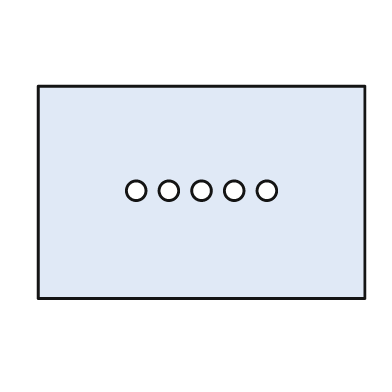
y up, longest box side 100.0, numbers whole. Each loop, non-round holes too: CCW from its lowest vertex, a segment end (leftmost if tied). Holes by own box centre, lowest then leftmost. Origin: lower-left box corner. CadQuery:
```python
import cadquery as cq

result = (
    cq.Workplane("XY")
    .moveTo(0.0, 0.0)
    .lineTo(100.0, 0.0)
    .lineTo(100.0, 65.0)
    .lineTo(0.0, 65.0)
    .close()
    .moveTo(30.0, 33.0)
    .circle(3.0)
    .moveTo(40.0, 33.0)
    .circle(3.0)
    .moveTo(50.0, 33.0)
    .circle(3.0)
    .moveTo(60.0, 33.0)
    .circle(3.0)
    .moveTo(70.0, 33.0)
    .circle(3.0)
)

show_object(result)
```